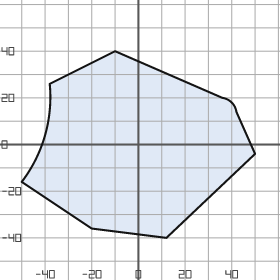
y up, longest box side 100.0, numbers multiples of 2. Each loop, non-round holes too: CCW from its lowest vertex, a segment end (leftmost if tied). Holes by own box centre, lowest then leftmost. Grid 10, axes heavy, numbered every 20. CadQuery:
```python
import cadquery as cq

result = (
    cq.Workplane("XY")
    .moveTo(12.0, -40.0)
    .lineTo(50.0, -4.0)
    .lineTo(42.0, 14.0)
    .threePointArc((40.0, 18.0), (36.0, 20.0))
    .lineTo(-10.0, 40.0)
    .lineTo(-38.0, 26.0)
    .threePointArc((-40.0, 4.0), (-50.0, -16.0))
    .lineTo(-20.0, -36.0)
    .close()
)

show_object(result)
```